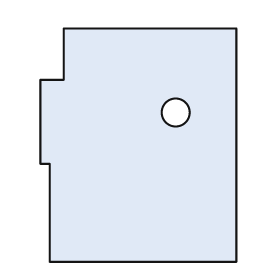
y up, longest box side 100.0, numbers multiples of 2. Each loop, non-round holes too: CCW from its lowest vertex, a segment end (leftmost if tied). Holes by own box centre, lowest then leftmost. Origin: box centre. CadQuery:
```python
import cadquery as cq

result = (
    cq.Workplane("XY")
    .moveTo(-38.0, -50.0)
    .lineTo(42.0, -50.0)
    .lineTo(42.0, 50.0)
    .lineTo(-32.0, 50.0)
    .lineTo(-32.0, 28.0)
    .lineTo(-42.0, 28.0)
    .lineTo(-42.0, -8.0)
    .lineTo(-38.0, -8.0)
    .close()
    .moveTo(16.0, 14.0)
    .circle(6.0)
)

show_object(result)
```